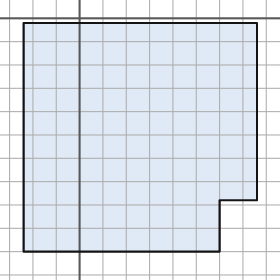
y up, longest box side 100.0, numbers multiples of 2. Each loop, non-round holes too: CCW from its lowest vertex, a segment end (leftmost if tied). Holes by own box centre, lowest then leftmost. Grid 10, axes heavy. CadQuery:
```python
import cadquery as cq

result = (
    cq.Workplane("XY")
    .moveTo(-24.0, -100.0)
    .lineTo(60.0, -100.0)
    .lineTo(60.0, -78.0)
    .lineTo(76.0, -78.0)
    .lineTo(76.0, -2.0)
    .lineTo(-24.0, -2.0)
    .close()
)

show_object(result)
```